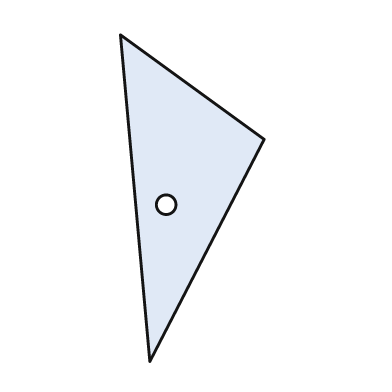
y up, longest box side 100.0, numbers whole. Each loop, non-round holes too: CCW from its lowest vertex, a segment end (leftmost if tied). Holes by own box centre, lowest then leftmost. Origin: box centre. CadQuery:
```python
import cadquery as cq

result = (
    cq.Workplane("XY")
    .moveTo(-13.0, -50.0)
    .lineTo(22.0, 18.0)
    .lineTo(-22.0, 50.0)
    .close()
    .moveTo(-8.0, -2.0)
    .circle(3.0)
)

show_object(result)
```